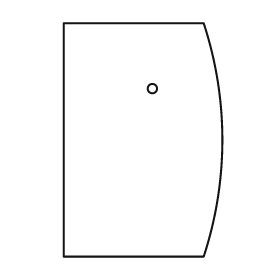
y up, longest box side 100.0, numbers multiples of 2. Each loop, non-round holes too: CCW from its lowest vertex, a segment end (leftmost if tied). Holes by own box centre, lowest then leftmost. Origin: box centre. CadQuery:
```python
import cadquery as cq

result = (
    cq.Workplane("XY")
    .moveTo(-34.0, -50.0)
    .lineTo(26.0, -50.0)
    .threePointArc((34.0, 0.0), (26.0, 50.0))
    .lineTo(-34.0, 50.0)
    .close()
    .moveTo(4.0, 22.0)
    .circle(2.0)
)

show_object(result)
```